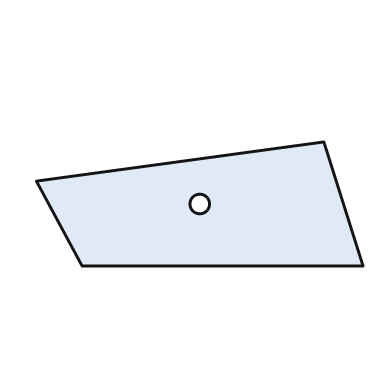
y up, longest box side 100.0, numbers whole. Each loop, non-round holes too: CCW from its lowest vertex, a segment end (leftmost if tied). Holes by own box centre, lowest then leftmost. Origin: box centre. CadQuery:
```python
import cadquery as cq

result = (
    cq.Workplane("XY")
    .moveTo(-36.0, -19.0)
    .lineTo(50.0, -19.0)
    .lineTo(38.0, 19.0)
    .lineTo(-50.0, 7.0)
    .close()
    .moveTo(0.0, 0.0)
    .circle(3.0)
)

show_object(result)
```